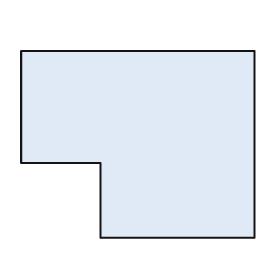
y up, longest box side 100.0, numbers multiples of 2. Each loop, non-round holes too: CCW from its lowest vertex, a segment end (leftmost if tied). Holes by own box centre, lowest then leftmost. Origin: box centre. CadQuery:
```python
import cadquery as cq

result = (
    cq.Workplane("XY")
    .moveTo(-16.0, -40.0)
    .lineTo(50.0, -40.0)
    .lineTo(50.0, 40.0)
    .lineTo(-50.0, 40.0)
    .lineTo(-50.0, -8.0)
    .lineTo(-16.0, -8.0)
    .close()
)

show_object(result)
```